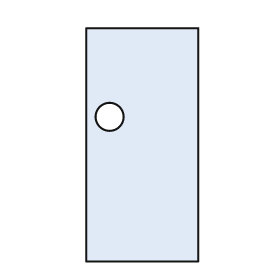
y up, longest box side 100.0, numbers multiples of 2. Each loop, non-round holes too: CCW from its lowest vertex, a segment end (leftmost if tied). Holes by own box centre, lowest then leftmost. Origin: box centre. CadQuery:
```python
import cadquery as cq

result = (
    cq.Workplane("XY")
    .moveTo(-24.0, -50.0)
    .lineTo(24.0, -50.0)
    .lineTo(24.0, 50.0)
    .lineTo(-24.0, 50.0)
    .close()
    .moveTo(-14.0, 12.0)
    .circle(6.0)
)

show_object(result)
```